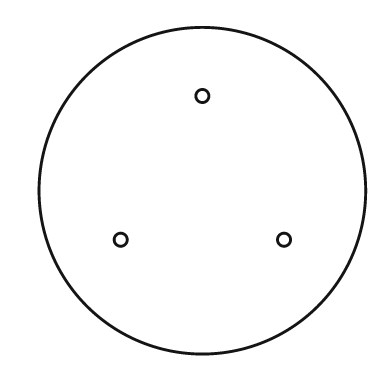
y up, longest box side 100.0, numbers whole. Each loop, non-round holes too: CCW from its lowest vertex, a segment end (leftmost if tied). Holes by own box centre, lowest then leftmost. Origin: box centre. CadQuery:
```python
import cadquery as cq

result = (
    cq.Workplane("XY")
    .moveTo(0.0, 0.0)
    .circle(50.0)
    .moveTo(-25.0, -15.0)
    .circle(2.0)
    .moveTo(25.0, -15.0)
    .circle(2.0)
    .moveTo(0.0, 29.0)
    .circle(2.0)
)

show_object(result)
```